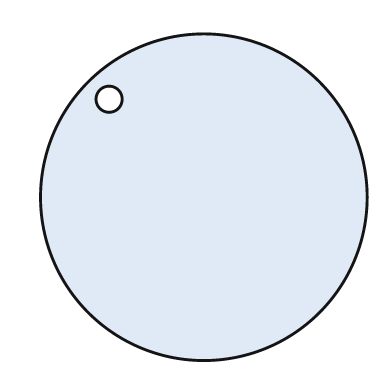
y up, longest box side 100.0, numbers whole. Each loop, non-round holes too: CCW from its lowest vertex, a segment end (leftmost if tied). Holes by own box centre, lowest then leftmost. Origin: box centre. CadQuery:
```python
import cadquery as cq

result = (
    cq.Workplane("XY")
    .moveTo(0.0, 0.0)
    .circle(50.0)
    .moveTo(-29.0, 30.0)
    .circle(4.0)
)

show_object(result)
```